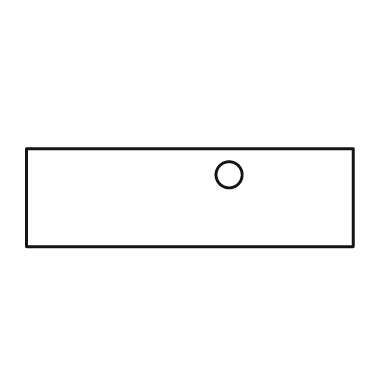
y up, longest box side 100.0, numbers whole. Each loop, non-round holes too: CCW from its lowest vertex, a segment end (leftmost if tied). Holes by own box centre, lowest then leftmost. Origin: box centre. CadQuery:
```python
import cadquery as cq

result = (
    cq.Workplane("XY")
    .moveTo(-50.0, -15.0)
    .lineTo(50.0, -15.0)
    .lineTo(50.0, 15.0)
    .lineTo(-50.0, 15.0)
    .close()
    .moveTo(12.0, 7.0)
    .circle(4.0)
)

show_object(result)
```